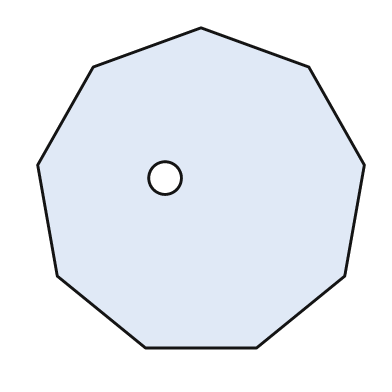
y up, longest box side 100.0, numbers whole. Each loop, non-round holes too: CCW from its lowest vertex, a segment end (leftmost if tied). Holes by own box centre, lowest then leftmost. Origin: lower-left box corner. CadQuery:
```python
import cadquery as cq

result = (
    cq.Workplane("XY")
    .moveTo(33.0, 0.0)
    .lineTo(67.0, 0.0)
    .lineTo(94.0, 22.0)
    .lineTo(100.0, 56.0)
    .lineTo(83.0, 86.0)
    .lineTo(50.0, 98.0)
    .lineTo(17.0, 86.0)
    .lineTo(0.0, 56.0)
    .lineTo(6.0, 22.0)
    .close()
    .moveTo(39.0, 52.0)
    .circle(5.0)
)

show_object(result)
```